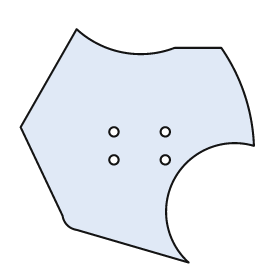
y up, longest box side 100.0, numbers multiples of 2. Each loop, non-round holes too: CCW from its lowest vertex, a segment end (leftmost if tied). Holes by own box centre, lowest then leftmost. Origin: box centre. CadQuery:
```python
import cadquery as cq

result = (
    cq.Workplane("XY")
    .moveTo(22.0, -50.0)
    .threePointArc((16.0, -14.0), (50.0, 0.0))
    .threePointArc((46.0, 22.0), (36.0, 42.0))
    .lineTo(16.0, 42.0)
    .threePointArc((-6.0, 40.0), (-26.0, 50.0))
    .lineTo(-50.0, 8.0)
    .lineTo(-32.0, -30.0)
    .threePointArc((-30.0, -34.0), (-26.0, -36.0))
    .close()
    .moveTo(-10.0, -6.0)
    .circle(2.0)
    .moveTo(12.0, -6.0)
    .circle(2.0)
    .moveTo(-10.0, 6.0)
    .circle(2.0)
    .moveTo(12.0, 6.0)
    .circle(2.0)
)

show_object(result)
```